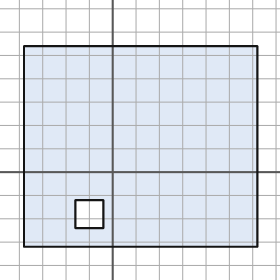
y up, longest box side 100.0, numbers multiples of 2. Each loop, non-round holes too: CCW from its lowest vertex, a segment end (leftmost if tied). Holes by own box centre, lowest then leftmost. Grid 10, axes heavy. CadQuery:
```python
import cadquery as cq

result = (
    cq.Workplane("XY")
    .moveTo(-38.0, -32.0)
    .lineTo(62.0, -32.0)
    .lineTo(62.0, 54.0)
    .lineTo(-38.0, 54.0)
    .close()
    .moveTo(-16.0, -24.0)
    .lineTo(-4.0, -24.0)
    .lineTo(-4.0, -12.0)
    .lineTo(-16.0, -12.0)
    .close()
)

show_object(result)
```